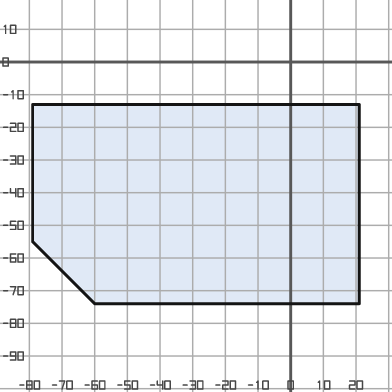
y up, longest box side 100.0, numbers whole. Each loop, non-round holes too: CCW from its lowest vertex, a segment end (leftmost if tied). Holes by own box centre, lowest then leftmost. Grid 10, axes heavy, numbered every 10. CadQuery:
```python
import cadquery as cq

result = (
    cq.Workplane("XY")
    .moveTo(-60.0, -74.0)
    .lineTo(21.0, -74.0)
    .lineTo(21.0, -13.0)
    .lineTo(-79.0, -13.0)
    .lineTo(-79.0, -55.0)
    .close()
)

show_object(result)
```